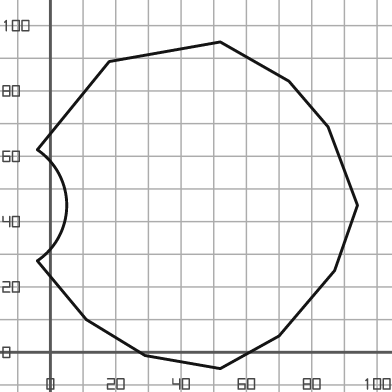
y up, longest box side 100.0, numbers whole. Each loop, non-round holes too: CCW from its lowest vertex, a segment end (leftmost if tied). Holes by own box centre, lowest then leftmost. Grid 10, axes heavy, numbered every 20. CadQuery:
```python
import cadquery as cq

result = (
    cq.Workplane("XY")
    .moveTo(52.0, -5.0)
    .lineTo(70.0, 5.0)
    .lineTo(87.0, 25.0)
    .lineTo(94.0, 45.0)
    .lineTo(85.0, 69.0)
    .lineTo(73.0, 83.0)
    .lineTo(52.0, 95.0)
    .lineTo(18.0, 89.0)
    .lineTo(-4.0, 62.0)
    .threePointArc((5.0, 45.0), (-4.0, 28.0))
    .lineTo(11.0, 10.0)
    .lineTo(29.0, -1.0)
    .close()
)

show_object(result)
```